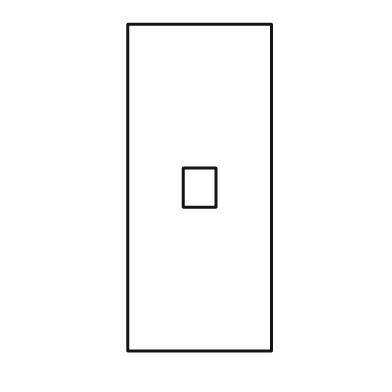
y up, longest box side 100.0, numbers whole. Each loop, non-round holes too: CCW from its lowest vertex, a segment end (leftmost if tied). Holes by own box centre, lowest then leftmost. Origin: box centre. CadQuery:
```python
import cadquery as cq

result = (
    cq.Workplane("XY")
    .moveTo(-22.0, -50.0)
    .lineTo(22.0, -50.0)
    .lineTo(22.0, 50.0)
    .lineTo(-22.0, 50.0)
    .close()
    .moveTo(-5.0, -6.0)
    .lineTo(5.0, -6.0)
    .lineTo(5.0, 6.0)
    .lineTo(-5.0, 6.0)
    .close()
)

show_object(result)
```